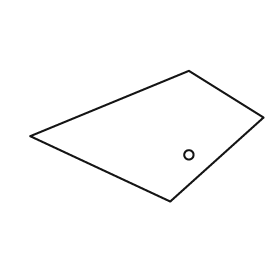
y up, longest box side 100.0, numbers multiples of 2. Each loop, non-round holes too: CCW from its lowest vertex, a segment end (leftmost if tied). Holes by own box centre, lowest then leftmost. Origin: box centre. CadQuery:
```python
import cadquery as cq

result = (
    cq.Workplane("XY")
    .moveTo(10.0, -28.0)
    .lineTo(50.0, 8.0)
    .lineTo(18.0, 28.0)
    .lineTo(-50.0, 0.0)
    .close()
    .moveTo(18.0, -8.0)
    .circle(2.0)
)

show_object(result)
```